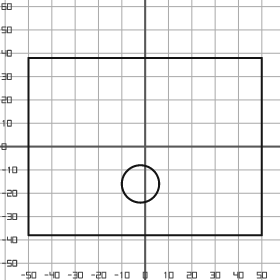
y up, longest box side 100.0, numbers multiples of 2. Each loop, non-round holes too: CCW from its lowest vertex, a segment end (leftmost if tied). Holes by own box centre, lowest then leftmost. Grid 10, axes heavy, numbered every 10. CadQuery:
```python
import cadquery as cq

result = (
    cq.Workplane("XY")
    .moveTo(-50.0, -38.0)
    .lineTo(50.0, -38.0)
    .lineTo(50.0, 38.0)
    .lineTo(-50.0, 38.0)
    .close()
    .moveTo(-2.0, -16.0)
    .circle(8.0)
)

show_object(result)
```